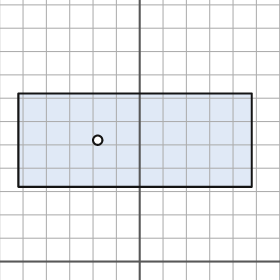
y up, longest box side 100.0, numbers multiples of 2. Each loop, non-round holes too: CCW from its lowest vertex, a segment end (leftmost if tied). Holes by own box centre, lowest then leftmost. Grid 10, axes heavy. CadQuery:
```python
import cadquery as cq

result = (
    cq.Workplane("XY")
    .moveTo(-52.0, 32.0)
    .lineTo(48.0, 32.0)
    .lineTo(48.0, 72.0)
    .lineTo(-52.0, 72.0)
    .close()
    .moveTo(-18.0, 52.0)
    .circle(2.0)
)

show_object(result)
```